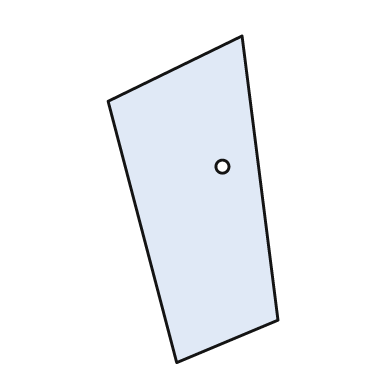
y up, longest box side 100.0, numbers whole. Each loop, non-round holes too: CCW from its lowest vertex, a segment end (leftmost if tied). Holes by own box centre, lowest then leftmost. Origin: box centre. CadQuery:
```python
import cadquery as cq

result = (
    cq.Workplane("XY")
    .moveTo(-5.0, -50.0)
    .lineTo(26.0, -37.0)
    .lineTo(15.0, 50.0)
    .lineTo(-26.0, 30.0)
    .close()
    .moveTo(9.0, 10.0)
    .circle(2.0)
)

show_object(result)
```